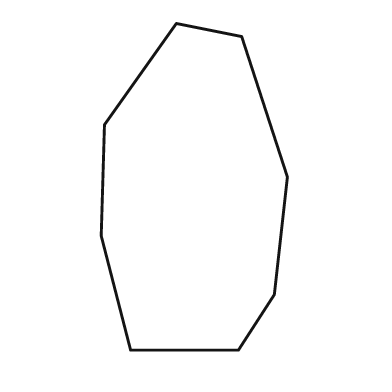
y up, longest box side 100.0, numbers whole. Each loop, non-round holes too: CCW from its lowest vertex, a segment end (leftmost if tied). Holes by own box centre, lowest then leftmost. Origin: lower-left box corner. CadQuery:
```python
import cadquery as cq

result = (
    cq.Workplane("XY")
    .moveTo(9.0, 0.0)
    .lineTo(42.0, 0.0)
    .lineTo(53.0, 17.0)
    .lineTo(57.0, 53.0)
    .lineTo(43.0, 96.0)
    .lineTo(23.0, 100.0)
    .lineTo(1.0, 69.0)
    .lineTo(0.0, 35.0)
    .close()
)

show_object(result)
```